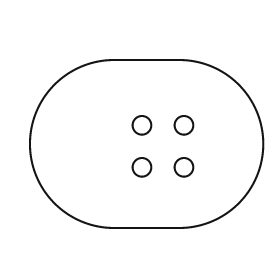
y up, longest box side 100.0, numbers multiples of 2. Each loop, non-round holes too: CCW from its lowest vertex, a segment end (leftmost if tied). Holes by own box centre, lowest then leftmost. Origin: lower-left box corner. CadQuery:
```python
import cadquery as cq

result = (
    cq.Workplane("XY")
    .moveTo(36.0, 0.0)
    .lineTo(64.0, 0.0)
    .threePointArc((100.0, 36.0), (64.0, 72.0))
    .lineTo(36.0, 72.0)
    .threePointArc((0.0, 36.0), (36.0, 0.0))
    .close()
    .moveTo(48.0, 26.0)
    .circle(4.0)
    .moveTo(66.0, 26.0)
    .circle(4.0)
    .moveTo(48.0, 44.0)
    .circle(4.0)
    .moveTo(66.0, 44.0)
    .circle(4.0)
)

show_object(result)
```